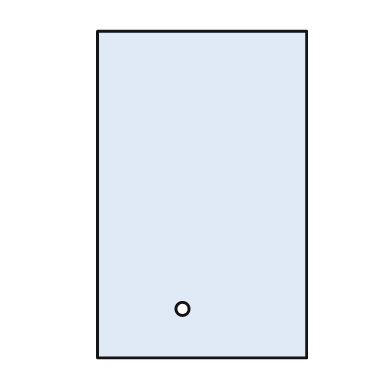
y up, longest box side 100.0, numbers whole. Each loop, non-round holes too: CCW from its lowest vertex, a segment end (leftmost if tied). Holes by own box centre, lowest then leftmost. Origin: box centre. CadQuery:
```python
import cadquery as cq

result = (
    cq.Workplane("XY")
    .moveTo(-32.0, -50.0)
    .lineTo(32.0, -50.0)
    .lineTo(32.0, 50.0)
    .lineTo(-32.0, 50.0)
    .close()
    .moveTo(-6.0, -35.0)
    .circle(2.0)
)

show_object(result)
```